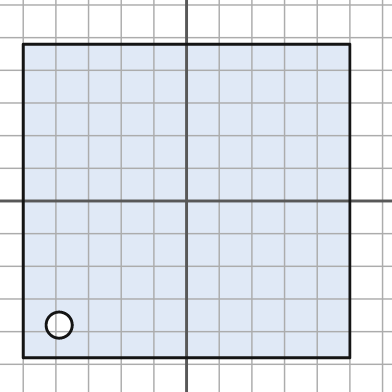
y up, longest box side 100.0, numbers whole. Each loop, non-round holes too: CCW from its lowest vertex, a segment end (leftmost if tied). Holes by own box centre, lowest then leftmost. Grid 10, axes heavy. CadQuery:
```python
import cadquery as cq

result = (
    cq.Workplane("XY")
    .moveTo(-50.0, -48.0)
    .lineTo(50.0, -48.0)
    .lineTo(50.0, 48.0)
    .lineTo(-50.0, 48.0)
    .close()
    .moveTo(-39.0, -38.0)
    .circle(4.0)
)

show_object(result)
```